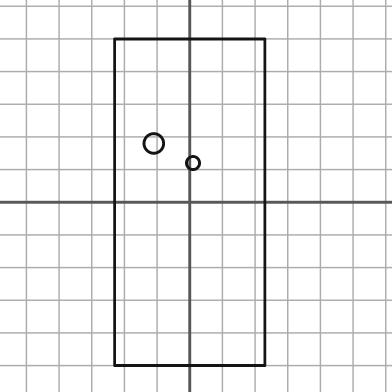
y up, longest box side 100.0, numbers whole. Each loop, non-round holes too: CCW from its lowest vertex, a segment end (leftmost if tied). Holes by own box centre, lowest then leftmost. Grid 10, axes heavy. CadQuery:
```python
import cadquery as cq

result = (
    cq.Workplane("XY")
    .moveTo(-23.0, -50.0)
    .lineTo(23.0, -50.0)
    .lineTo(23.0, 50.0)
    .lineTo(-23.0, 50.0)
    .close()
    .moveTo(1.0, 12.0)
    .circle(2.0)
    .moveTo(-11.0, 18.0)
    .circle(3.0)
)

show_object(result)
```